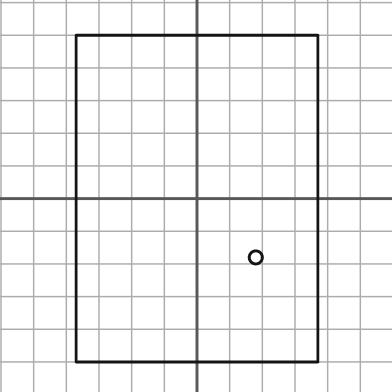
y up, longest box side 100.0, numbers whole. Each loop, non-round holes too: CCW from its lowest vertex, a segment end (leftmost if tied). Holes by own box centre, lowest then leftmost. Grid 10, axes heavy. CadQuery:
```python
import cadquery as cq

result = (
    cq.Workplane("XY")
    .moveTo(-37.0, -50.0)
    .lineTo(37.0, -50.0)
    .lineTo(37.0, 50.0)
    .lineTo(-37.0, 50.0)
    .close()
    .moveTo(18.0, -18.0)
    .circle(2.0)
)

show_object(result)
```